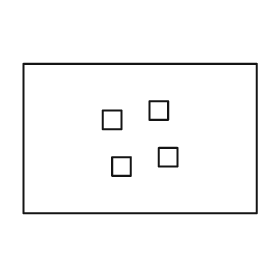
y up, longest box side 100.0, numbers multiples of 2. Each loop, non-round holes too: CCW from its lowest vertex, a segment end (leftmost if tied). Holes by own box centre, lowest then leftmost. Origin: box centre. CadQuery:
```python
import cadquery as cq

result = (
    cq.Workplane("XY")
    .moveTo(-50.0, -32.0)
    .lineTo(50.0, -32.0)
    .lineTo(50.0, 32.0)
    .lineTo(-50.0, 32.0)
    .close()
    .moveTo(-12.0, -16.0)
    .lineTo(-4.0, -16.0)
    .lineTo(-4.0, -8.0)
    .lineTo(-12.0, -8.0)
    .close()
    .moveTo(8.0, -12.0)
    .lineTo(16.0, -12.0)
    .lineTo(16.0, -4.0)
    .lineTo(8.0, -4.0)
    .close()
    .moveTo(-16.0, 4.0)
    .lineTo(-8.0, 4.0)
    .lineTo(-8.0, 12.0)
    .lineTo(-16.0, 12.0)
    .close()
    .moveTo(4.0, 8.0)
    .lineTo(12.0, 8.0)
    .lineTo(12.0, 16.0)
    .lineTo(4.0, 16.0)
    .close()
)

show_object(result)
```